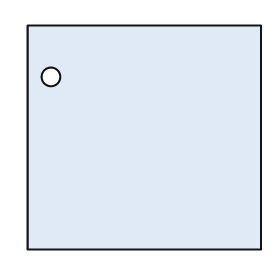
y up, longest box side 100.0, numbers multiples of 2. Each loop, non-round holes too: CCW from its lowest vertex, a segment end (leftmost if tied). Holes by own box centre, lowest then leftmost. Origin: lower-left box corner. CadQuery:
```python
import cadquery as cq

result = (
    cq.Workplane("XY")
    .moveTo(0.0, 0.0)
    .lineTo(100.0, 0.0)
    .lineTo(100.0, 96.0)
    .lineTo(0.0, 96.0)
    .close()
    .moveTo(10.0, 74.0)
    .circle(4.0)
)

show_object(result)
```